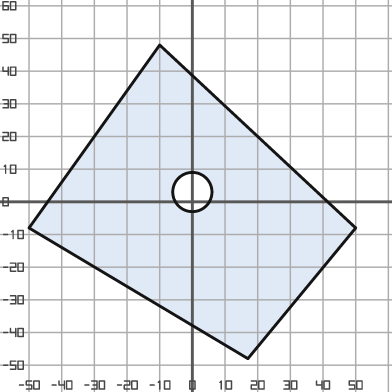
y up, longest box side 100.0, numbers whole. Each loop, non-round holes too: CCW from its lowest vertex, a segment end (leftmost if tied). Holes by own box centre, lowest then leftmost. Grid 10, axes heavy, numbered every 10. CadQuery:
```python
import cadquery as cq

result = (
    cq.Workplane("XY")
    .moveTo(17.0, -48.0)
    .lineTo(50.0, -8.0)
    .lineTo(-10.0, 48.0)
    .lineTo(-50.0, -8.0)
    .close()
    .moveTo(0.0, 3.0)
    .circle(6.0)
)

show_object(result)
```